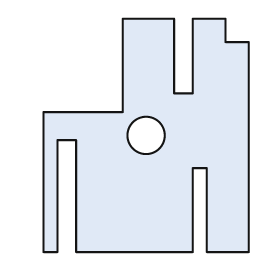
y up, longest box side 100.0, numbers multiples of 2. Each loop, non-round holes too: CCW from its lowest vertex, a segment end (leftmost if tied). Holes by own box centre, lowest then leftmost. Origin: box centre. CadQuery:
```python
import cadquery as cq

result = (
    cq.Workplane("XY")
    .moveTo(-44.0, -50.0)
    .lineTo(-38.0, -50.0)
    .lineTo(-38.0, -2.0)
    .lineTo(-30.0, -2.0)
    .lineTo(-30.0, -50.0)
    .lineTo(20.0, -50.0)
    .lineTo(20.0, -14.0)
    .lineTo(26.0, -14.0)
    .lineTo(26.0, -50.0)
    .lineTo(44.0, -50.0)
    .lineTo(44.0, 40.0)
    .lineTo(34.0, 40.0)
    .lineTo(34.0, 50.0)
    .lineTo(20.0, 50.0)
    .lineTo(20.0, 18.0)
    .lineTo(12.0, 18.0)
    .lineTo(12.0, 50.0)
    .lineTo(-10.0, 50.0)
    .lineTo(-10.0, 10.0)
    .lineTo(-44.0, 10.0)
    .close()
    .moveTo(0.0, 0.0)
    .circle(8.0)
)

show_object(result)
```